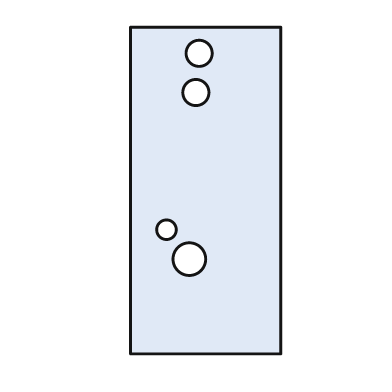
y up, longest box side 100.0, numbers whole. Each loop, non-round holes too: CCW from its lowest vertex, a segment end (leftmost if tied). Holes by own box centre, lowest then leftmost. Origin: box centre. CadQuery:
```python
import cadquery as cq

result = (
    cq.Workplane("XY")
    .moveTo(-23.0, -50.0)
    .lineTo(23.0, -50.0)
    .lineTo(23.0, 50.0)
    .lineTo(-23.0, 50.0)
    .close()
    .moveTo(-5.0, -21.0)
    .circle(5.0)
    .moveTo(-12.0, -12.0)
    .circle(3.0)
    .moveTo(-3.0, 30.0)
    .circle(4.0)
    .moveTo(-2.0, 42.0)
    .circle(4.0)
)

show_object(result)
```